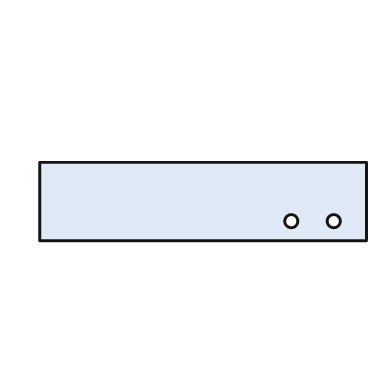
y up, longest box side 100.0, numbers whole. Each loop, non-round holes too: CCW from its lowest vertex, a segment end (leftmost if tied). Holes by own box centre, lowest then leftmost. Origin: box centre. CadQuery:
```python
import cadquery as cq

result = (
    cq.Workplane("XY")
    .moveTo(-50.0, -12.0)
    .lineTo(50.0, -12.0)
    .lineTo(50.0, 12.0)
    .lineTo(-50.0, 12.0)
    .close()
    .moveTo(27.0, -6.0)
    .circle(2.0)
    .moveTo(40.0, -6.0)
    .circle(2.0)
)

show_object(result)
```